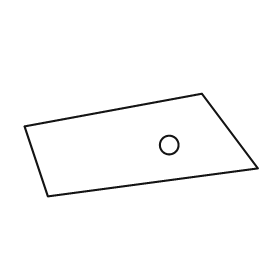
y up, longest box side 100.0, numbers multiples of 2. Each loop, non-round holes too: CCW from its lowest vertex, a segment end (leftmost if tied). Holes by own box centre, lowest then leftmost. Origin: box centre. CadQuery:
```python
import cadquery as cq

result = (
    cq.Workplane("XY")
    .moveTo(-40.0, -22.0)
    .lineTo(50.0, -10.0)
    .lineTo(26.0, 22.0)
    .lineTo(-50.0, 8.0)
    .close()
    .moveTo(12.0, 0.0)
    .circle(4.0)
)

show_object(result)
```